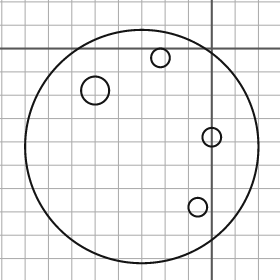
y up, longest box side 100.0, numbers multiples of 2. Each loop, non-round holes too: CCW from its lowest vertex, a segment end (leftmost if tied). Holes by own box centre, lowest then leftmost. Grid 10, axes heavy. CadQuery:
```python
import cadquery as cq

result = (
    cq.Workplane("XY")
    .moveTo(-30.0, -42.0)
    .circle(50.0)
    .moveTo(-6.0, -68.0)
    .circle(4.0)
    .moveTo(0.0, -38.0)
    .circle(4.0)
    .moveTo(-50.0, -18.0)
    .circle(6.0)
    .moveTo(-22.0, -4.0)
    .circle(4.0)
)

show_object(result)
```